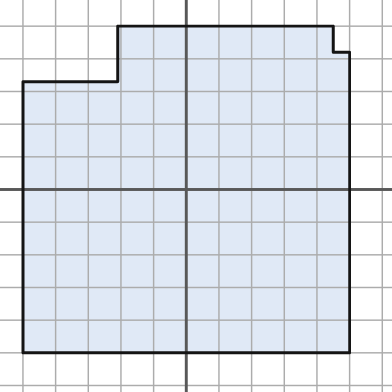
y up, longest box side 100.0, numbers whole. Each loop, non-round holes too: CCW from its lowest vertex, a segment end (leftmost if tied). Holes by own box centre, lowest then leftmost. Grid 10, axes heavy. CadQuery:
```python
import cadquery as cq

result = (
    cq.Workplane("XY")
    .moveTo(-50.0, -50.0)
    .lineTo(50.0, -50.0)
    .lineTo(50.0, 42.0)
    .lineTo(45.0, 42.0)
    .lineTo(45.0, 50.0)
    .lineTo(-21.0, 50.0)
    .lineTo(-21.0, 33.0)
    .lineTo(-50.0, 33.0)
    .close()
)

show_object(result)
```